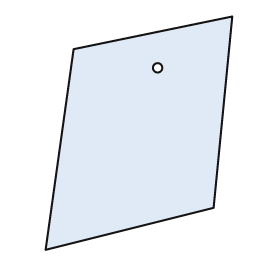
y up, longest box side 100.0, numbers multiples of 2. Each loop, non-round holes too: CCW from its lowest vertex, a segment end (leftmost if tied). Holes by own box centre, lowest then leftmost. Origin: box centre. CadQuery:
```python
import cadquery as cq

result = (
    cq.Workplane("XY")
    .moveTo(-40.0, -50.0)
    .lineTo(32.0, -32.0)
    .lineTo(40.0, 50.0)
    .lineTo(-28.0, 36.0)
    .close()
    .moveTo(8.0, 28.0)
    .circle(2.0)
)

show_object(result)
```